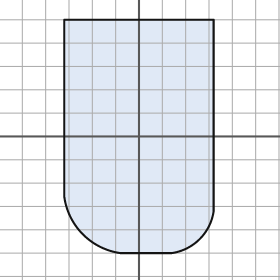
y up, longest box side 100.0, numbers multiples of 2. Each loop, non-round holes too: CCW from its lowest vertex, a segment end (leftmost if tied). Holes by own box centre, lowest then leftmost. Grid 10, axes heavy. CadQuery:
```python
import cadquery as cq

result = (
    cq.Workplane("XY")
    .moveTo(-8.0, -50.0)
    .lineTo(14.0, -50.0)
    .threePointArc((26.0, -44.0), (32.0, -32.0))
    .lineTo(32.0, 50.0)
    .lineTo(-32.0, 50.0)
    .lineTo(-32.0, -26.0)
    .threePointArc((-24.0, -42.0), (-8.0, -50.0))
    .close()
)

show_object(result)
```